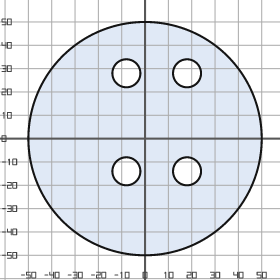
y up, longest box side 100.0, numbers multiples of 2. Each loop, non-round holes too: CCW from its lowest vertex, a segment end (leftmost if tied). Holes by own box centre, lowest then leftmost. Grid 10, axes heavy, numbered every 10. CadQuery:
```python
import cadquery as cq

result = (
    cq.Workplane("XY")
    .moveTo(0.0, 0.0)
    .circle(50.0)
    .moveTo(-8.0, -14.0)
    .circle(6.0)
    .moveTo(18.0, -14.0)
    .circle(6.0)
    .moveTo(-8.0, 28.0)
    .circle(6.0)
    .moveTo(18.0, 28.0)
    .circle(6.0)
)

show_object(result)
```